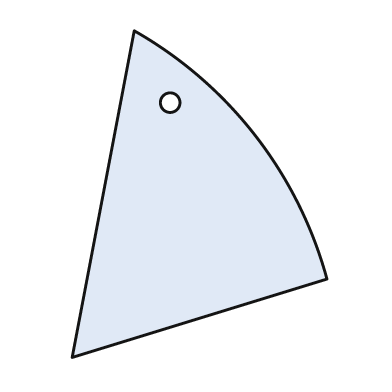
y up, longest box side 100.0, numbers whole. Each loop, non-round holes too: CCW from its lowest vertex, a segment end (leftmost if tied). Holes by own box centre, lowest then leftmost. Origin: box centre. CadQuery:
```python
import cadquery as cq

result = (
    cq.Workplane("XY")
    .moveTo(-39.0, -50.0)
    .lineTo(39.0, -26.0)
    .threePointArc((17.0, 18.0), (-20.0, 50.0))
    .close()
    .moveTo(-9.0, 28.0)
    .circle(3.0)
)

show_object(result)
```